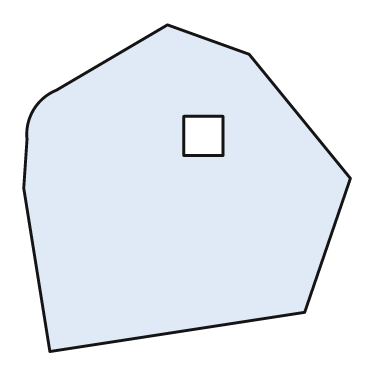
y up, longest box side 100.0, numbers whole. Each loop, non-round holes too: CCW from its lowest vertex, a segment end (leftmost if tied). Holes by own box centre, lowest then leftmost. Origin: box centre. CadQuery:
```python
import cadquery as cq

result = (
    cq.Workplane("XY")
    .moveTo(-42.0, -50.0)
    .lineTo(36.0, -38.0)
    .lineTo(50.0, 3.0)
    .lineTo(19.0, 41.0)
    .lineTo(-6.0, 50.0)
    .lineTo(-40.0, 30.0)
    .threePointArc((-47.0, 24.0), (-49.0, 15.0))
    .lineTo(-50.0, 0.0)
    .close()
    .moveTo(-1.0, 10.0)
    .lineTo(11.0, 10.0)
    .lineTo(11.0, 22.0)
    .lineTo(-1.0, 22.0)
    .close()
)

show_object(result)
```